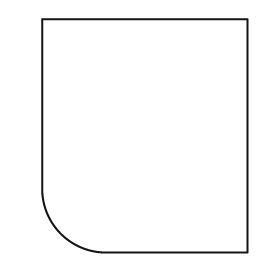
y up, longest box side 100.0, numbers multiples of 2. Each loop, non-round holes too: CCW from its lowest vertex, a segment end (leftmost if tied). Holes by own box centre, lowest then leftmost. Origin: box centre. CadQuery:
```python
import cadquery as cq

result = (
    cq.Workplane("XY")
    .moveTo(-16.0, -50.0)
    .lineTo(44.0, -50.0)
    .lineTo(44.0, 50.0)
    .lineTo(-44.0, 50.0)
    .lineTo(-44.0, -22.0)
    .threePointArc((-36.0, -42.0), (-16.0, -50.0))
    .close()
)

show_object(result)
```